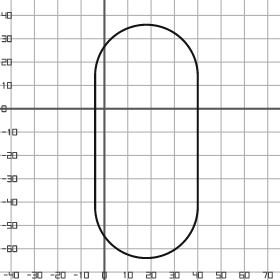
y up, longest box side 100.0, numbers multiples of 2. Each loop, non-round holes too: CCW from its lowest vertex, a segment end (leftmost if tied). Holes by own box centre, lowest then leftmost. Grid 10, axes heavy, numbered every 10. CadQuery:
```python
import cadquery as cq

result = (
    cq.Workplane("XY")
    .moveTo(-4.0, -42.0)
    .threePointArc((18.0, -64.0), (40.0, -42.0))
    .lineTo(40.0, 14.0)
    .threePointArc((18.0, 36.0), (-4.0, 14.0))
    .close()
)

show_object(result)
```